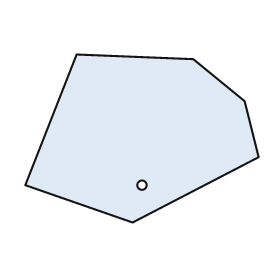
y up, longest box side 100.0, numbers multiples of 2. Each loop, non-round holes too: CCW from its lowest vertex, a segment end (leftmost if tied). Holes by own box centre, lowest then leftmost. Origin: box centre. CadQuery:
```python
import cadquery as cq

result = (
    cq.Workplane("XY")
    .moveTo(-4.0, -36.0)
    .lineTo(50.0, -8.0)
    .lineTo(44.0, 16.0)
    .lineTo(22.0, 34.0)
    .lineTo(-28.0, 36.0)
    .lineTo(-50.0, -20.0)
    .close()
    .moveTo(0.0, -20.0)
    .circle(2.0)
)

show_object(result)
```